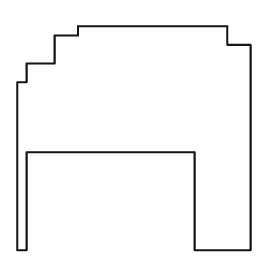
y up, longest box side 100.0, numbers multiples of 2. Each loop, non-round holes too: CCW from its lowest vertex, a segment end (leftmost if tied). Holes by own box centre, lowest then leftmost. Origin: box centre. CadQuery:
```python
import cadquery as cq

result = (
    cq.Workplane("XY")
    .moveTo(-50.0, -48.0)
    .lineTo(-46.0, -48.0)
    .lineTo(-46.0, -6.0)
    .lineTo(26.0, -6.0)
    .lineTo(26.0, -48.0)
    .lineTo(50.0, -48.0)
    .lineTo(50.0, 40.0)
    .lineTo(40.0, 40.0)
    .lineTo(40.0, 48.0)
    .lineTo(-24.0, 48.0)
    .lineTo(-24.0, 44.0)
    .lineTo(-34.0, 44.0)
    .lineTo(-34.0, 32.0)
    .lineTo(-46.0, 32.0)
    .lineTo(-46.0, 24.0)
    .lineTo(-50.0, 24.0)
    .close()
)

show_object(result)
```